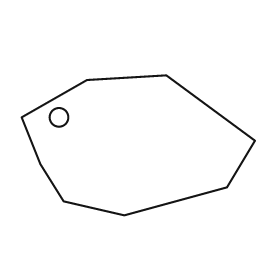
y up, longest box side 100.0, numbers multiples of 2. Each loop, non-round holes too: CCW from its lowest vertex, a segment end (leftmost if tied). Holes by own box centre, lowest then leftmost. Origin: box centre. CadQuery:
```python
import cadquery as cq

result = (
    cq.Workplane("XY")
    .moveTo(-6.0, -30.0)
    .lineTo(38.0, -18.0)
    .lineTo(50.0, 2.0)
    .lineTo(12.0, 30.0)
    .lineTo(-22.0, 28.0)
    .lineTo(-50.0, 12.0)
    .lineTo(-42.0, -8.0)
    .lineTo(-32.0, -24.0)
    .close()
    .moveTo(-34.0, 12.0)
    .circle(4.0)
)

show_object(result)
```